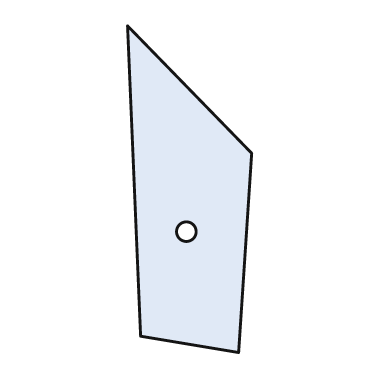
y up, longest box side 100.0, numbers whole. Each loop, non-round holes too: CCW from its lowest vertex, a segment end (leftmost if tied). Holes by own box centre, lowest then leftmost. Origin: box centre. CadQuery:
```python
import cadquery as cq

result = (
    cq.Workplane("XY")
    .moveTo(15.0, -50.0)
    .lineTo(19.0, 11.0)
    .lineTo(-19.0, 50.0)
    .lineTo(-15.0, -45.0)
    .close()
    .moveTo(-1.0, -13.0)
    .circle(3.0)
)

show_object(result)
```